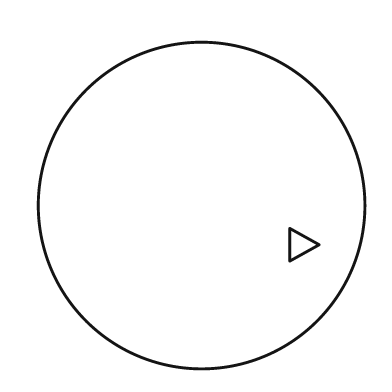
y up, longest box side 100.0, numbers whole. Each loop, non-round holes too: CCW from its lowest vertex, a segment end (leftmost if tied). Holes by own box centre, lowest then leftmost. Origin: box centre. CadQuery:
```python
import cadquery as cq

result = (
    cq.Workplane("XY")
    .moveTo(0.0, 0.0)
    .circle(50.0)
    .moveTo(27.0, -17.0)
    .lineTo(36.0, -12.0)
    .lineTo(27.0, -7.0)
    .close()
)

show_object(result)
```